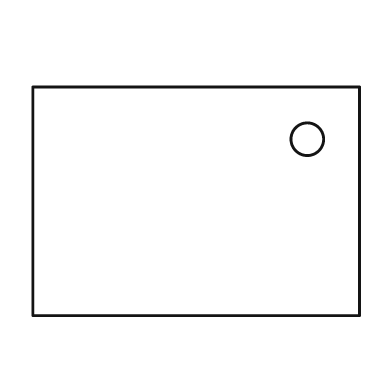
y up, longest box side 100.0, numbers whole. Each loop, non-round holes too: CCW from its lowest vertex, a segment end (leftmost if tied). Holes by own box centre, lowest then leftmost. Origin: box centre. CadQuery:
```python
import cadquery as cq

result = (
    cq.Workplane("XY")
    .moveTo(-50.0, -35.0)
    .lineTo(50.0, -35.0)
    .lineTo(50.0, 35.0)
    .lineTo(-50.0, 35.0)
    .close()
    .moveTo(34.0, 19.0)
    .circle(5.0)
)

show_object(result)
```